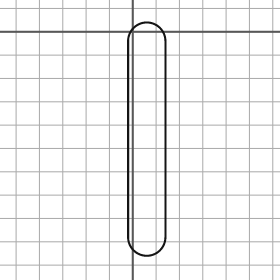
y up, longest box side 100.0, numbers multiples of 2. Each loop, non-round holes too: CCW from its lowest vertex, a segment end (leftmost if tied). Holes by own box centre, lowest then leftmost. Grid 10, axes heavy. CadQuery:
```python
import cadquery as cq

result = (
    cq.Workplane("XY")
    .moveTo(-2.0, -88.0)
    .threePointArc((6.0, -96.0), (14.0, -88.0))
    .lineTo(14.0, -4.0)
    .threePointArc((6.0, 4.0), (-2.0, -4.0))
    .close()
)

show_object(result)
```